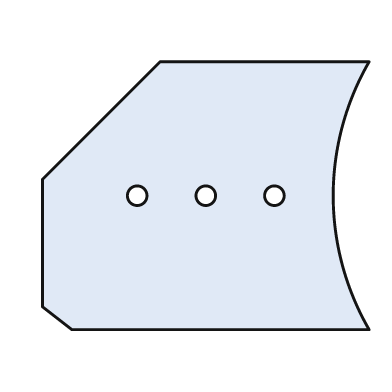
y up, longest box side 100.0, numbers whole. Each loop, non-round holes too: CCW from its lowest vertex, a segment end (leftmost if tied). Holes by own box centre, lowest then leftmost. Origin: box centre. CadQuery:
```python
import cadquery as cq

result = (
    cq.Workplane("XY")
    .moveTo(-41.0, -41.0)
    .lineTo(50.0, -41.0)
    .threePointArc((39.0, 0.0), (50.0, 41.0))
    .lineTo(-14.0, 41.0)
    .lineTo(-50.0, 5.0)
    .lineTo(-50.0, -34.0)
    .close()
    .moveTo(-21.0, 0.0)
    .circle(3.0)
    .moveTo(0.0, 0.0)
    .circle(3.0)
    .moveTo(21.0, 0.0)
    .circle(3.0)
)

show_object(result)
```